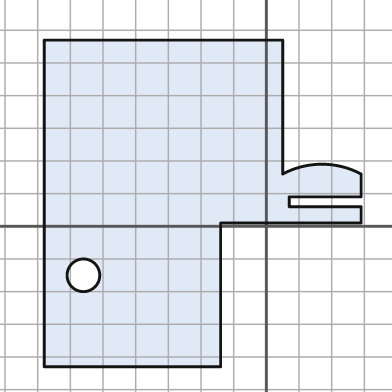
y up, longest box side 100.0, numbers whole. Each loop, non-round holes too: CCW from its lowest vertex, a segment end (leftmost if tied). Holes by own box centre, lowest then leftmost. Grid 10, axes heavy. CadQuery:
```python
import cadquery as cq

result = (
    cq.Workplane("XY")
    .moveTo(-68.0, -43.0)
    .lineTo(-14.0, -43.0)
    .lineTo(-14.0, 1.0)
    .lineTo(29.0, 1.0)
    .lineTo(29.0, 6.0)
    .lineTo(7.0, 6.0)
    .lineTo(7.0, 9.0)
    .lineTo(29.0, 9.0)
    .lineTo(29.0, 16.0)
    .threePointArc((17.0, 19.0), (5.0, 16.0))
    .lineTo(5.0, 57.0)
    .lineTo(-68.0, 57.0)
    .close()
    .moveTo(-56.0, -15.0)
    .circle(5.0)
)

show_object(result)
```